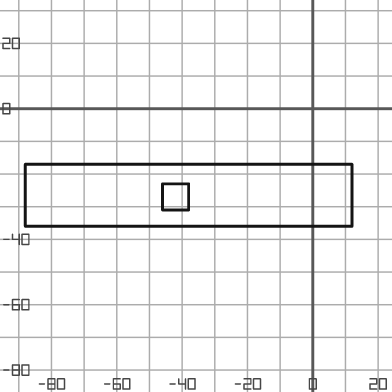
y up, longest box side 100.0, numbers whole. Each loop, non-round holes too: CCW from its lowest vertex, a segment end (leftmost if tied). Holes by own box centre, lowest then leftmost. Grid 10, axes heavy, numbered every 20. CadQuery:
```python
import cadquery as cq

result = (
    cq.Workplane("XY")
    .moveTo(-88.0, -36.0)
    .lineTo(12.0, -36.0)
    .lineTo(12.0, -17.0)
    .lineTo(-88.0, -17.0)
    .close()
    .moveTo(-46.0, -31.0)
    .lineTo(-38.0, -31.0)
    .lineTo(-38.0, -23.0)
    .lineTo(-46.0, -23.0)
    .close()
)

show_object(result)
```